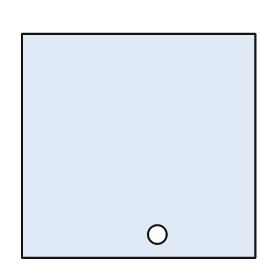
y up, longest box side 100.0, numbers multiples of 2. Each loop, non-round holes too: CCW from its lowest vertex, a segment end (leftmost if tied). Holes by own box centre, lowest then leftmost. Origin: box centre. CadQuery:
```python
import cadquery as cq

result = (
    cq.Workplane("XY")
    .moveTo(-50.0, -48.0)
    .lineTo(50.0, -48.0)
    .lineTo(50.0, 48.0)
    .lineTo(-50.0, 48.0)
    .close()
    .moveTo(8.0, -38.0)
    .circle(4.0)
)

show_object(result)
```